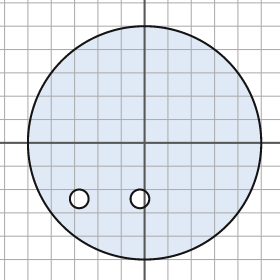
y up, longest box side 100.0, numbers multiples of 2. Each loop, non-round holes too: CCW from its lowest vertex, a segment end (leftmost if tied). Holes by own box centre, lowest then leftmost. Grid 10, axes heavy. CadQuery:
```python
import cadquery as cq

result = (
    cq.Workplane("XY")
    .moveTo(0.0, 0.0)
    .circle(50.0)
    .moveTo(-28.0, -24.0)
    .circle(4.0)
    .moveTo(-2.0, -24.0)
    .circle(4.0)
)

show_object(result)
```